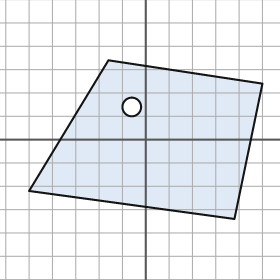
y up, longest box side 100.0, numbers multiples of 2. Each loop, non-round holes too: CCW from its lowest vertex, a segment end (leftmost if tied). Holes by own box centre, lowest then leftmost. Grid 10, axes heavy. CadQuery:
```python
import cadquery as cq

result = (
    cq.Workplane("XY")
    .moveTo(38.0, -34.0)
    .lineTo(50.0, 24.0)
    .lineTo(-16.0, 34.0)
    .lineTo(-50.0, -22.0)
    .close()
    .moveTo(-6.0, 14.0)
    .circle(4.0)
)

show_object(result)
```